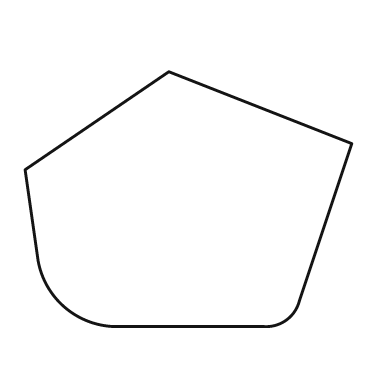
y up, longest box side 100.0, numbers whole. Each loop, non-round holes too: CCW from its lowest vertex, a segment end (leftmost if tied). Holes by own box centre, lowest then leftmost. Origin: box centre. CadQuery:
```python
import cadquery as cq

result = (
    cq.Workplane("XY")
    .moveTo(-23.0, -39.0)
    .lineTo(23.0, -39.0)
    .threePointArc((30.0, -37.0), (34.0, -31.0))
    .lineTo(50.0, 17.0)
    .lineTo(-6.0, 39.0)
    .lineTo(-50.0, 9.0)
    .lineTo(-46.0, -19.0)
    .threePointArc((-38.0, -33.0), (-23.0, -39.0))
    .close()
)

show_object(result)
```